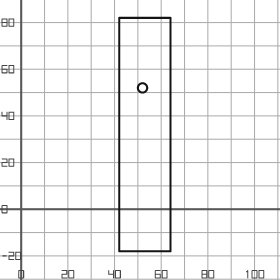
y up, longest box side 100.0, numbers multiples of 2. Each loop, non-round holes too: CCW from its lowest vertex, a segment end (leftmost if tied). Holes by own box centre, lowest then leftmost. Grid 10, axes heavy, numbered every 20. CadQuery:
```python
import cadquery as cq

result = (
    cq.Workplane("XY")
    .moveTo(42.0, -18.0)
    .lineTo(64.0, -18.0)
    .lineTo(64.0, 82.0)
    .lineTo(42.0, 82.0)
    .close()
    .moveTo(52.0, 52.0)
    .circle(2.0)
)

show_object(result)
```